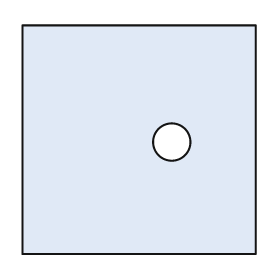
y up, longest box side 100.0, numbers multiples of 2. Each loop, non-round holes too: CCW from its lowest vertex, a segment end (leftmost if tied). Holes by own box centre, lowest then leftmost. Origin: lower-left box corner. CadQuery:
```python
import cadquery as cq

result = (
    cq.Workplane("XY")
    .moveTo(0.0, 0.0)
    .lineTo(100.0, 0.0)
    .lineTo(100.0, 98.0)
    .lineTo(0.0, 98.0)
    .close()
    .moveTo(64.0, 48.0)
    .circle(8.0)
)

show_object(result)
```